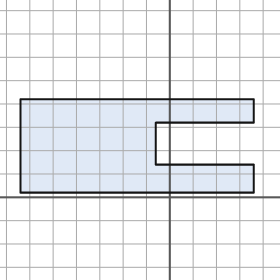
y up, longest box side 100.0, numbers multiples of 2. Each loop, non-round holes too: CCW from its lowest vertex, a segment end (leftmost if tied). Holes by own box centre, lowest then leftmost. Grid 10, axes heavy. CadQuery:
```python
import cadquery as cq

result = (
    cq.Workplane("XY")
    .moveTo(-64.0, 2.0)
    .lineTo(36.0, 2.0)
    .lineTo(36.0, 14.0)
    .lineTo(-6.0, 14.0)
    .lineTo(-6.0, 32.0)
    .lineTo(36.0, 32.0)
    .lineTo(36.0, 42.0)
    .lineTo(-64.0, 42.0)
    .close()
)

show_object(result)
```